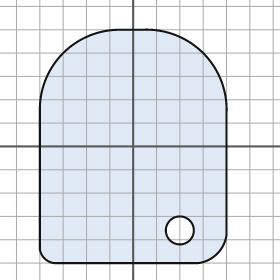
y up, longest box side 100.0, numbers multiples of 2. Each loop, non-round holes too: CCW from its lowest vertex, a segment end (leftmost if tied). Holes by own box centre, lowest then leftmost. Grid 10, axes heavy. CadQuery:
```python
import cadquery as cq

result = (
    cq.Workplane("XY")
    .moveTo(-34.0, -50.0)
    .lineTo(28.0, -50.0)
    .threePointArc((36.0, -46.0), (40.0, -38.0))
    .lineTo(40.0, 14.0)
    .threePointArc((30.0, 40.0), (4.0, 50.0))
    .lineTo(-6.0, 50.0)
    .threePointArc((-30.0, 40.0), (-40.0, 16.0))
    .lineTo(-40.0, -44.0)
    .threePointArc((-38.0, -48.0), (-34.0, -50.0))
    .close()
    .moveTo(20.0, -36.0)
    .circle(6.0)
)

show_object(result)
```